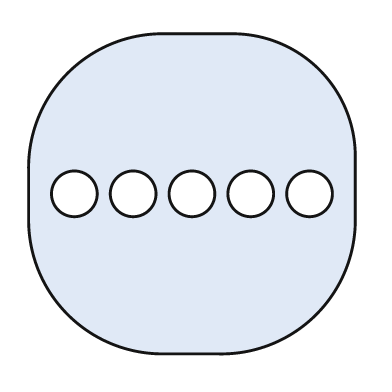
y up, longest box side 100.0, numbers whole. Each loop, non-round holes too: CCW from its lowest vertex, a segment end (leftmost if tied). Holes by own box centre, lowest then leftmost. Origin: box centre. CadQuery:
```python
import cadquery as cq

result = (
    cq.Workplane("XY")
    .moveTo(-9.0, -49.0)
    .lineTo(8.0, -49.0)
    .threePointArc((38.0, -37.0), (50.0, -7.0))
    .lineTo(50.0, 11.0)
    .threePointArc((39.0, 38.0), (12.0, 49.0))
    .lineTo(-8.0, 49.0)
    .threePointArc((-38.0, 37.0), (-50.0, 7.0))
    .lineTo(-50.0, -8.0)
    .threePointArc((-38.0, -37.0), (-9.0, -49.0))
    .close()
    .moveTo(-36.0, 0.0)
    .circle(7.0)
    .moveTo(-18.0, 0.0)
    .circle(7.0)
    .moveTo(0.0, 0.0)
    .circle(7.0)
    .moveTo(18.0, 0.0)
    .circle(7.0)
    .moveTo(36.0, 0.0)
    .circle(7.0)
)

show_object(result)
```